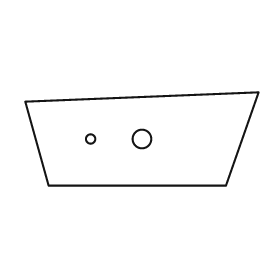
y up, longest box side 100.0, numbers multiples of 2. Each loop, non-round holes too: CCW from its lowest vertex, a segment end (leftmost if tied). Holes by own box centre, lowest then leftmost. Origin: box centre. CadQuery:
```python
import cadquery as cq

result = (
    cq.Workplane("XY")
    .moveTo(-40.0, -20.0)
    .lineTo(36.0, -20.0)
    .lineTo(50.0, 20.0)
    .lineTo(-50.0, 16.0)
    .close()
    .moveTo(-22.0, 0.0)
    .circle(2.0)
    .moveTo(0.0, 0.0)
    .circle(4.0)
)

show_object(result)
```